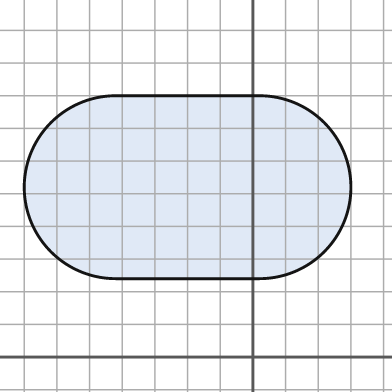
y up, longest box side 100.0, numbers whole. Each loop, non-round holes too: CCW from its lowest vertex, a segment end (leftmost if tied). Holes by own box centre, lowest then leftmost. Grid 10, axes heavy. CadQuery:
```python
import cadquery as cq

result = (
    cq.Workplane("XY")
    .moveTo(-42.0, 24.0)
    .lineTo(2.0, 24.0)
    .threePointArc((30.0, 52.0), (2.0, 80.0))
    .lineTo(-42.0, 80.0)
    .threePointArc((-70.0, 52.0), (-42.0, 24.0))
    .close()
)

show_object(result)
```